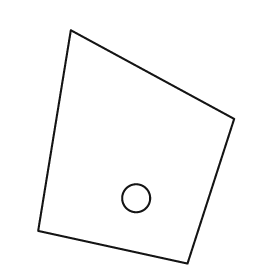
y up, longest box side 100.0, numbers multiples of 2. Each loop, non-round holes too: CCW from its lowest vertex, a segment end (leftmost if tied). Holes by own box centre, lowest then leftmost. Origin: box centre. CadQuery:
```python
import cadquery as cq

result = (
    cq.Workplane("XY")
    .moveTo(22.0, -50.0)
    .lineTo(42.0, 12.0)
    .lineTo(-28.0, 50.0)
    .lineTo(-42.0, -36.0)
    .close()
    .moveTo(0.0, -22.0)
    .circle(6.0)
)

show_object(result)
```